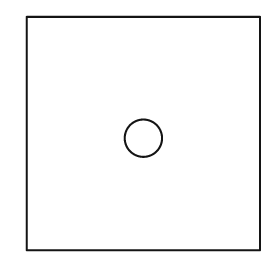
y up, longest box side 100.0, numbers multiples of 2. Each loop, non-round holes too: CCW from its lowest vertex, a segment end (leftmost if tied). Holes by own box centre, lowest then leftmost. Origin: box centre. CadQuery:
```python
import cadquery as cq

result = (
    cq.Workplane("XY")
    .moveTo(-50.0, -50.0)
    .lineTo(50.0, -50.0)
    .lineTo(50.0, 50.0)
    .lineTo(-50.0, 50.0)
    .close()
    .moveTo(0.0, -2.0)
    .circle(8.0)
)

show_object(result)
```